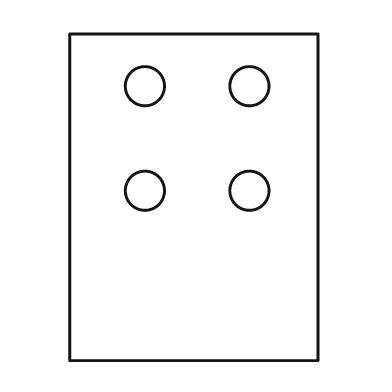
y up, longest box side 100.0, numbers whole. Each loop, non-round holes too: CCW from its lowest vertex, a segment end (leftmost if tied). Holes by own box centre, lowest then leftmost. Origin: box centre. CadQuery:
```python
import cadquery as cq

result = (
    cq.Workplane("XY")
    .moveTo(-38.0, -50.0)
    .lineTo(38.0, -50.0)
    .lineTo(38.0, 50.0)
    .lineTo(-38.0, 50.0)
    .close()
    .moveTo(-15.0, 2.0)
    .circle(6.0)
    .moveTo(17.0, 2.0)
    .circle(6.0)
    .moveTo(-15.0, 34.0)
    .circle(6.0)
    .moveTo(17.0, 34.0)
    .circle(6.0)
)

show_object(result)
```